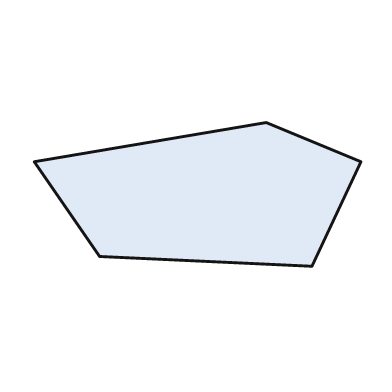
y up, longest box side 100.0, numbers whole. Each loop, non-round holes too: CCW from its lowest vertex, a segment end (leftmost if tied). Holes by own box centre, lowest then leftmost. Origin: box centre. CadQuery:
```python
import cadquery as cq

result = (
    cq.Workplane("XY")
    .moveTo(35.0, -22.0)
    .lineTo(50.0, 10.0)
    .lineTo(21.0, 22.0)
    .lineTo(-50.0, 10.0)
    .lineTo(-30.0, -19.0)
    .close()
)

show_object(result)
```